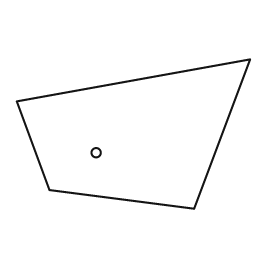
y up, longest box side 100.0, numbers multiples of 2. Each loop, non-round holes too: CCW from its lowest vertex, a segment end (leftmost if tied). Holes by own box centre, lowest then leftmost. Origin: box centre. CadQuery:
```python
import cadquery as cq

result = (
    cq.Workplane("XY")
    .moveTo(26.0, -32.0)
    .lineTo(50.0, 32.0)
    .lineTo(-50.0, 14.0)
    .lineTo(-36.0, -24.0)
    .close()
    .moveTo(-16.0, -8.0)
    .circle(2.0)
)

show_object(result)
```